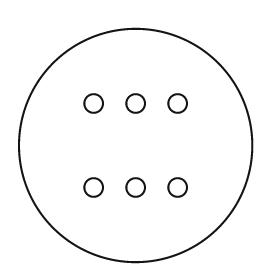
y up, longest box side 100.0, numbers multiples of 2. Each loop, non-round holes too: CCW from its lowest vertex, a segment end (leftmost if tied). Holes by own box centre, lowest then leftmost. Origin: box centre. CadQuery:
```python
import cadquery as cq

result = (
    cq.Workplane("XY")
    .moveTo(0.0, 0.0)
    .circle(50.0)
    .moveTo(-18.0, -18.0)
    .circle(4.0)
    .moveTo(0.0, -18.0)
    .circle(4.0)
    .moveTo(18.0, -18.0)
    .circle(4.0)
    .moveTo(-18.0, 18.0)
    .circle(4.0)
    .moveTo(0.0, 18.0)
    .circle(4.0)
    .moveTo(18.0, 18.0)
    .circle(4.0)
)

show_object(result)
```